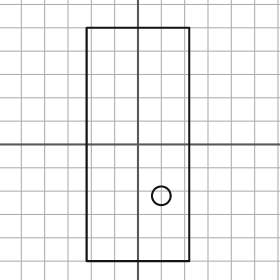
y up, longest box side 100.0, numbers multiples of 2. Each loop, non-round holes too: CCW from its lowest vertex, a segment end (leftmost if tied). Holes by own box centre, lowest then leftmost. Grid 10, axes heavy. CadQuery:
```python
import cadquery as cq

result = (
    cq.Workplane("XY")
    .moveTo(-22.0, -50.0)
    .lineTo(22.0, -50.0)
    .lineTo(22.0, 50.0)
    .lineTo(-22.0, 50.0)
    .close()
    .moveTo(10.0, -22.0)
    .circle(4.0)
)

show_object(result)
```